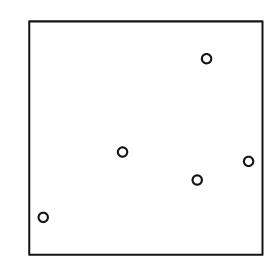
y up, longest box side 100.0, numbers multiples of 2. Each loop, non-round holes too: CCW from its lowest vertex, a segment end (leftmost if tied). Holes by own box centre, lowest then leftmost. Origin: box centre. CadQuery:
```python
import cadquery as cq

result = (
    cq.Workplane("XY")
    .moveTo(-50.0, -50.0)
    .lineTo(50.0, -50.0)
    .lineTo(50.0, 50.0)
    .lineTo(-50.0, 50.0)
    .close()
    .moveTo(-44.0, -34.0)
    .circle(2.0)
    .moveTo(22.0, -18.0)
    .circle(2.0)
    .moveTo(44.0, -10.0)
    .circle(2.0)
    .moveTo(-10.0, -6.0)
    .circle(2.0)
    .moveTo(26.0, 34.0)
    .circle(2.0)
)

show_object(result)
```